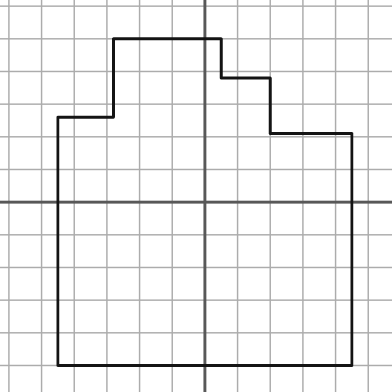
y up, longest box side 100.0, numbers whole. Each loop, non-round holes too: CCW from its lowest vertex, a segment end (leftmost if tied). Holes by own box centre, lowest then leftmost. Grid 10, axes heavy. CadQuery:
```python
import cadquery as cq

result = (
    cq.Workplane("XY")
    .moveTo(-45.0, -50.0)
    .lineTo(45.0, -50.0)
    .lineTo(45.0, 21.0)
    .lineTo(20.0, 21.0)
    .lineTo(20.0, 38.0)
    .lineTo(5.0, 38.0)
    .lineTo(5.0, 50.0)
    .lineTo(-28.0, 50.0)
    .lineTo(-28.0, 26.0)
    .lineTo(-45.0, 26.0)
    .close()
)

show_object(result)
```